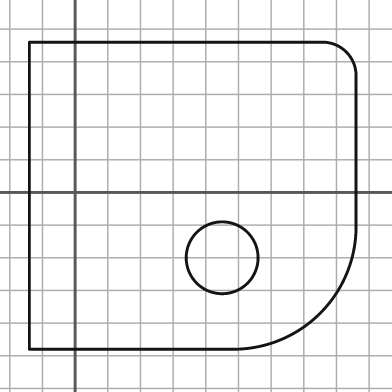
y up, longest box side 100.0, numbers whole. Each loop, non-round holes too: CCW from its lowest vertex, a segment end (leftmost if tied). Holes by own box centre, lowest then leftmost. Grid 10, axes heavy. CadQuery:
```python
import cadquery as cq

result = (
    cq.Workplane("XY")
    .moveTo(-14.0, -48.0)
    .lineTo(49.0, -48.0)
    .threePointArc((75.0, -37.0), (86.0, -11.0))
    .lineTo(86.0, 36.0)
    .threePointArc((83.0, 43.0), (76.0, 46.0))
    .lineTo(-14.0, 46.0)
    .close()
    .moveTo(45.0, -20.0)
    .circle(11.0)
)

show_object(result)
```